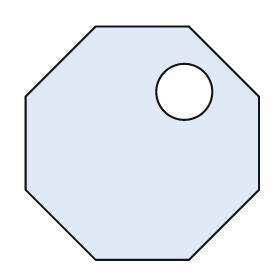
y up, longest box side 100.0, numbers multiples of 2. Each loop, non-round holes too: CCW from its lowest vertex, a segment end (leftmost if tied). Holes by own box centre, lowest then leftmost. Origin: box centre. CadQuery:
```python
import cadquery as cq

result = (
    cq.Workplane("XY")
    .moveTo(-20.0, -50.0)
    .lineTo(20.0, -50.0)
    .lineTo(50.0, -20.0)
    .lineTo(50.0, 20.0)
    .lineTo(20.0, 50.0)
    .lineTo(-20.0, 50.0)
    .lineTo(-50.0, 20.0)
    .lineTo(-50.0, -20.0)
    .close()
    .moveTo(18.0, 22.0)
    .circle(12.0)
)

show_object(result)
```